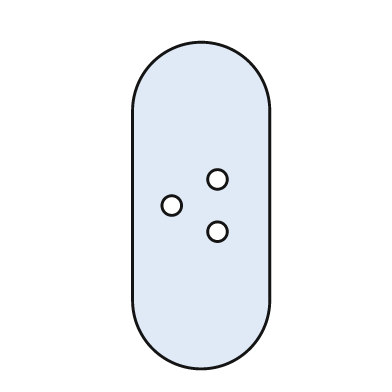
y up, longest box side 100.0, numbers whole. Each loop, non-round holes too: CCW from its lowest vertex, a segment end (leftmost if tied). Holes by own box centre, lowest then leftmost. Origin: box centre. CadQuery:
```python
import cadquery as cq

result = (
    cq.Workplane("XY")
    .moveTo(-21.0, -29.0)
    .threePointArc((0.0, -50.0), (21.0, -29.0))
    .lineTo(21.0, 29.0)
    .threePointArc((0.0, 50.0), (-21.0, 29.0))
    .close()
    .moveTo(5.0, -8.0)
    .circle(3.0)
    .moveTo(-9.0, 0.0)
    .circle(3.0)
    .moveTo(5.0, 8.0)
    .circle(3.0)
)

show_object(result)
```